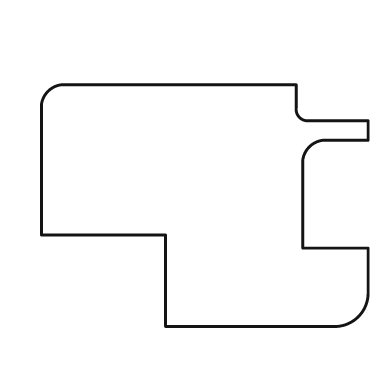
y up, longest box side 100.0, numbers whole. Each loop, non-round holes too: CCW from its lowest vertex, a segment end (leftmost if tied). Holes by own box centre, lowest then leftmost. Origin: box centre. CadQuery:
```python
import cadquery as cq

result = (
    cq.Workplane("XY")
    .moveTo(-12.0, -37.0)
    .lineTo(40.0, -37.0)
    .threePointArc((47.0, -34.0), (50.0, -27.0))
    .lineTo(50.0, -13.0)
    .lineTo(30.0, -13.0)
    .lineTo(30.0, 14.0)
    .threePointArc((32.0, 18.0), (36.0, 20.0))
    .lineTo(50.0, 20.0)
    .lineTo(50.0, 26.0)
    .lineTo(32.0, 26.0)
    .threePointArc((29.0, 27.0), (28.0, 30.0))
    .lineTo(28.0, 37.0)
    .lineTo(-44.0, 37.0)
    .threePointArc((-48.0, 35.0), (-50.0, 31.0))
    .lineTo(-50.0, -9.0)
    .lineTo(-12.0, -9.0)
    .close()
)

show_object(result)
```